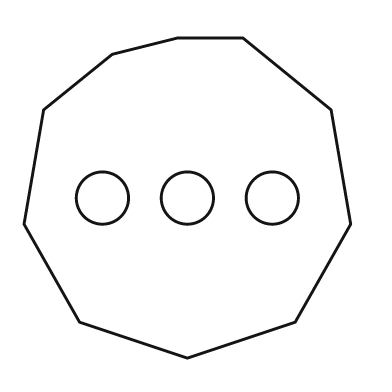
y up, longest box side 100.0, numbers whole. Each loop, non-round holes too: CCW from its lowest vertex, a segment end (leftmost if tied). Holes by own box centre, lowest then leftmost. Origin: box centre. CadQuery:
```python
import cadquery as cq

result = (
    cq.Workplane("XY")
    .moveTo(0.0, -49.0)
    .lineTo(33.0, -38.0)
    .lineTo(50.0, -8.0)
    .lineTo(44.0, 27.0)
    .lineTo(17.0, 49.0)
    .lineTo(-3.0, 49.0)
    .lineTo(-23.0, 44.0)
    .lineTo(-44.0, 27.0)
    .lineTo(-50.0, -8.0)
    .lineTo(-33.0, -38.0)
    .close()
    .moveTo(-26.0, 0.0)
    .circle(8.0)
    .moveTo(0.0, 0.0)
    .circle(8.0)
    .moveTo(26.0, 0.0)
    .circle(8.0)
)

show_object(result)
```